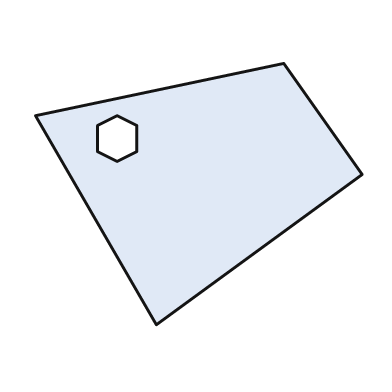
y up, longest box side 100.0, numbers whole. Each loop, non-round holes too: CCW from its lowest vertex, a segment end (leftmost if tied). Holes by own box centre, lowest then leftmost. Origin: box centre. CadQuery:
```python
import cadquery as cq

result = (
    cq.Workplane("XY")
    .moveTo(-13.0, -40.0)
    .lineTo(50.0, 6.0)
    .lineTo(26.0, 40.0)
    .lineTo(-50.0, 24.0)
    .close()
    .moveTo(-25.0, 10.0)
    .lineTo(-19.0, 13.0)
    .lineTo(-19.0, 21.0)
    .lineTo(-25.0, 24.0)
    .lineTo(-31.0, 21.0)
    .lineTo(-31.0, 13.0)
    .close()
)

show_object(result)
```